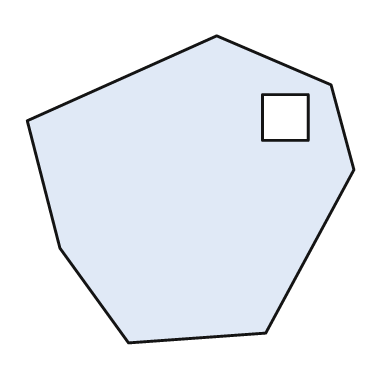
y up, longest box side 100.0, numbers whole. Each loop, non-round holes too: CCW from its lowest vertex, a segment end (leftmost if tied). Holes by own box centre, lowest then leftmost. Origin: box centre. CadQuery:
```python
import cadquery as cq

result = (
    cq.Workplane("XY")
    .moveTo(-19.0, -47.0)
    .lineTo(23.0, -44.0)
    .lineTo(50.0, 6.0)
    .lineTo(43.0, 32.0)
    .lineTo(8.0, 47.0)
    .lineTo(-50.0, 21.0)
    .lineTo(-40.0, -18.0)
    .close()
    .moveTo(22.0, 15.0)
    .lineTo(36.0, 15.0)
    .lineTo(36.0, 29.0)
    .lineTo(22.0, 29.0)
    .close()
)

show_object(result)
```